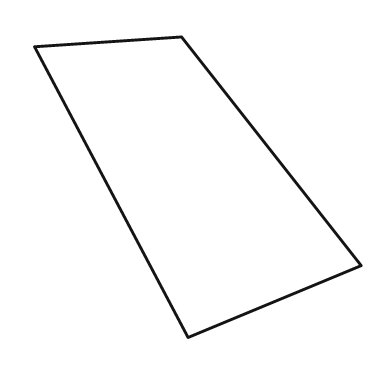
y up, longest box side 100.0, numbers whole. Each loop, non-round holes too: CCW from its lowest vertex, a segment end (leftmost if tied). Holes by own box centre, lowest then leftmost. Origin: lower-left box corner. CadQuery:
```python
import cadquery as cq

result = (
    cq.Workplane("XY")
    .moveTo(47.0, 0.0)
    .lineTo(100.0, 22.0)
    .lineTo(45.0, 92.0)
    .lineTo(0.0, 89.0)
    .close()
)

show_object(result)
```